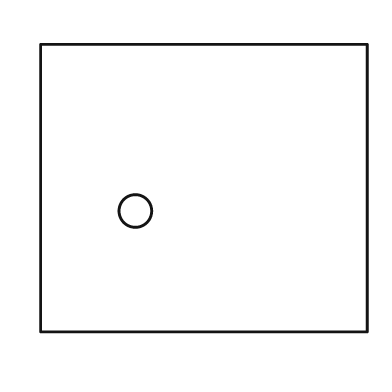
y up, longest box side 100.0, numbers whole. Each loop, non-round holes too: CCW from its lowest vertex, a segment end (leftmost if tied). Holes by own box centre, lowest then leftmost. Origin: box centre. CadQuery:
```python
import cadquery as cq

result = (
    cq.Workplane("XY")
    .moveTo(-50.0, -44.0)
    .lineTo(50.0, -44.0)
    .lineTo(50.0, 44.0)
    .lineTo(-50.0, 44.0)
    .close()
    .moveTo(-21.0, -7.0)
    .circle(5.0)
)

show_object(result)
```